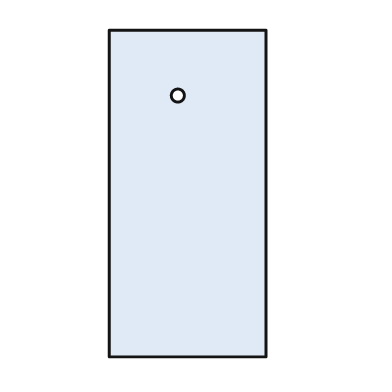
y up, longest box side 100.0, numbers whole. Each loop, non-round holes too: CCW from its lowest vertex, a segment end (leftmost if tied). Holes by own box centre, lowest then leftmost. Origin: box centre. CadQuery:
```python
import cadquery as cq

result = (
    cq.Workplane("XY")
    .moveTo(-24.0, -50.0)
    .lineTo(24.0, -50.0)
    .lineTo(24.0, 50.0)
    .lineTo(-24.0, 50.0)
    .close()
    .moveTo(-3.0, 30.0)
    .circle(2.0)
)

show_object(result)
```